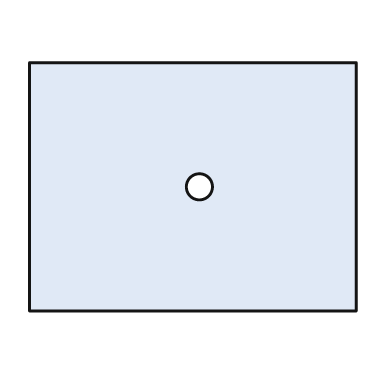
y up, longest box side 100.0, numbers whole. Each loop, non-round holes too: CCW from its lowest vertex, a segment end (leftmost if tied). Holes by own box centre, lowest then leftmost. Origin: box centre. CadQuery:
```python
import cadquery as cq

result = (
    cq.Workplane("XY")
    .moveTo(-50.0, -38.0)
    .lineTo(50.0, -38.0)
    .lineTo(50.0, 38.0)
    .lineTo(-50.0, 38.0)
    .close()
    .moveTo(2.0, 0.0)
    .circle(4.0)
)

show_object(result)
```